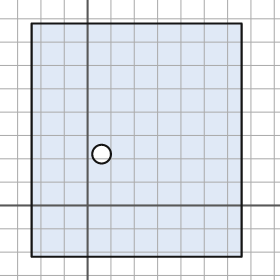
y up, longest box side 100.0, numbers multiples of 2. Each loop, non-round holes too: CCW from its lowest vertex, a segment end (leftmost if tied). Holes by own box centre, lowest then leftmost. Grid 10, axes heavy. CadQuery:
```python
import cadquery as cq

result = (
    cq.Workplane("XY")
    .moveTo(-24.0, -22.0)
    .lineTo(66.0, -22.0)
    .lineTo(66.0, 78.0)
    .lineTo(-24.0, 78.0)
    .close()
    .moveTo(6.0, 22.0)
    .circle(4.0)
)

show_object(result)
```